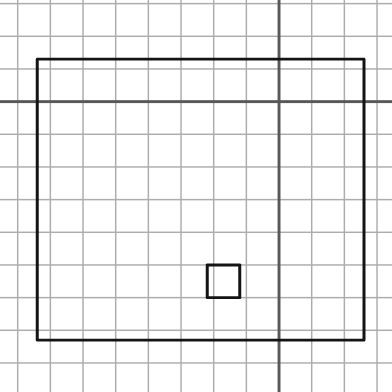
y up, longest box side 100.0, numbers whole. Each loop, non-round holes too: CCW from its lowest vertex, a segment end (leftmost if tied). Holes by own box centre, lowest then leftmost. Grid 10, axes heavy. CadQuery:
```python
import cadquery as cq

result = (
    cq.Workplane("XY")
    .moveTo(-74.0, -73.0)
    .lineTo(26.0, -73.0)
    .lineTo(26.0, 13.0)
    .lineTo(-74.0, 13.0)
    .close()
    .moveTo(-22.0, -60.0)
    .lineTo(-12.0, -60.0)
    .lineTo(-12.0, -50.0)
    .lineTo(-22.0, -50.0)
    .close()
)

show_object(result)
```